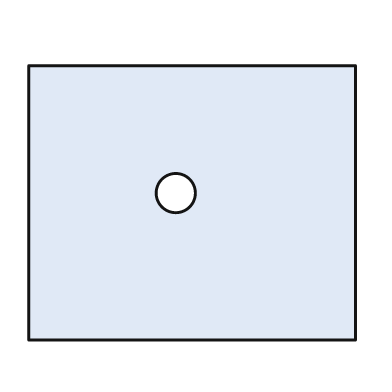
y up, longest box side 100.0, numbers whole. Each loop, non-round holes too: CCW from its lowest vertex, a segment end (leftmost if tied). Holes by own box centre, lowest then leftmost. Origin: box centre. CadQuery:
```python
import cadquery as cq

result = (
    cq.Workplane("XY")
    .moveTo(-50.0, -42.0)
    .lineTo(50.0, -42.0)
    .lineTo(50.0, 42.0)
    .lineTo(-50.0, 42.0)
    .close()
    .moveTo(-5.0, 3.0)
    .circle(6.0)
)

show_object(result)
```